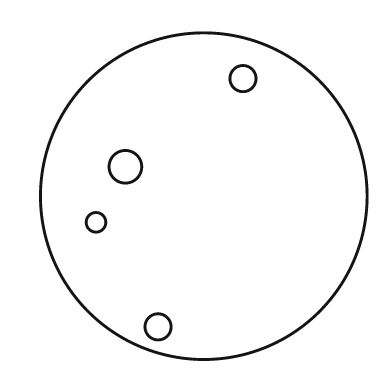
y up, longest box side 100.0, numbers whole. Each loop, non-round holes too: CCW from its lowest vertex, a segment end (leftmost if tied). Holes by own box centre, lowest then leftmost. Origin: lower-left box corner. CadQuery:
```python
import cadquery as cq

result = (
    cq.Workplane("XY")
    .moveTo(50.0, 50.0)
    .circle(50.0)
    .moveTo(36.0, 10.0)
    .circle(4.0)
    .moveTo(17.0, 42.0)
    .circle(3.0)
    .moveTo(26.0, 59.0)
    .circle(5.0)
    .moveTo(62.0, 86.0)
    .circle(4.0)
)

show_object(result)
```